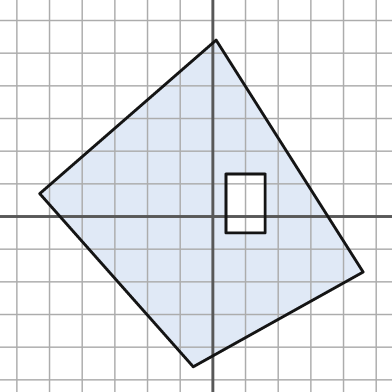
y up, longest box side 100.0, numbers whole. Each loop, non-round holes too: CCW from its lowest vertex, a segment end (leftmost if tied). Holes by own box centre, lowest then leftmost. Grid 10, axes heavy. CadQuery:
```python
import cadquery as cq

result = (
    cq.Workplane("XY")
    .moveTo(-6.0, -46.0)
    .lineTo(46.0, -17.0)
    .lineTo(1.0, 54.0)
    .lineTo(-53.0, 7.0)
    .close()
    .moveTo(4.0, -5.0)
    .lineTo(16.0, -5.0)
    .lineTo(16.0, 13.0)
    .lineTo(4.0, 13.0)
    .close()
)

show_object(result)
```